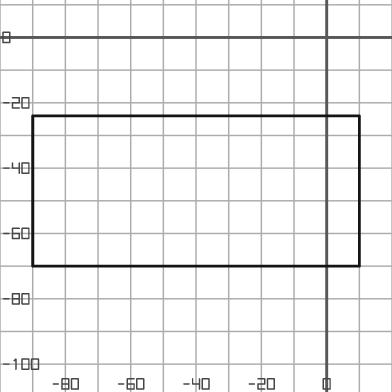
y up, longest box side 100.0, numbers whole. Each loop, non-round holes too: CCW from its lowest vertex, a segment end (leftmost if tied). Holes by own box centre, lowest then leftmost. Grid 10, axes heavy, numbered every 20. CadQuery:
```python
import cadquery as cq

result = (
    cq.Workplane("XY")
    .moveTo(-90.0, -70.0)
    .lineTo(10.0, -70.0)
    .lineTo(10.0, -24.0)
    .lineTo(-90.0, -24.0)
    .close()
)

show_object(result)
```